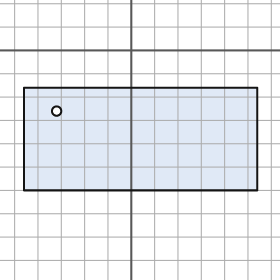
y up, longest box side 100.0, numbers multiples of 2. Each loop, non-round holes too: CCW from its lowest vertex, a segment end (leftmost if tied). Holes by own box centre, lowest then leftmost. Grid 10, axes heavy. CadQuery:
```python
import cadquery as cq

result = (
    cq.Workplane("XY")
    .moveTo(-46.0, -60.0)
    .lineTo(54.0, -60.0)
    .lineTo(54.0, -16.0)
    .lineTo(-46.0, -16.0)
    .close()
    .moveTo(-32.0, -26.0)
    .circle(2.0)
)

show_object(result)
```